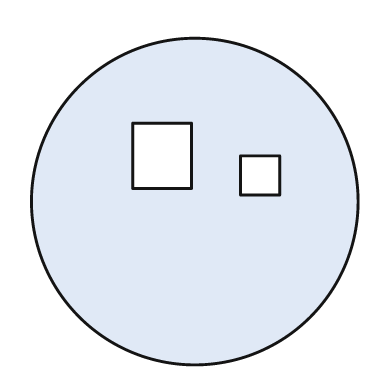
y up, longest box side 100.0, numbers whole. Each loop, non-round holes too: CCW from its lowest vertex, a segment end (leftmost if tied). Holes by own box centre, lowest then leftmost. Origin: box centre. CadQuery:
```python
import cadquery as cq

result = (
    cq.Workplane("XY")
    .moveTo(0.0, 0.0)
    .circle(50.0)
    .moveTo(14.0, 2.0)
    .lineTo(26.0, 2.0)
    .lineTo(26.0, 14.0)
    .lineTo(14.0, 14.0)
    .close()
    .moveTo(-19.0, 4.0)
    .lineTo(-1.0, 4.0)
    .lineTo(-1.0, 24.0)
    .lineTo(-19.0, 24.0)
    .close()
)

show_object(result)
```